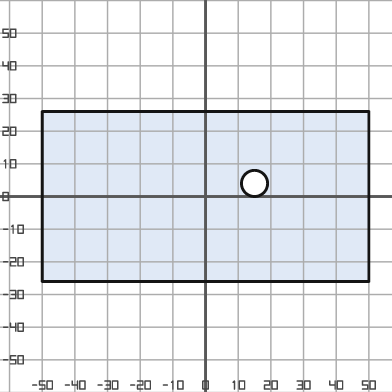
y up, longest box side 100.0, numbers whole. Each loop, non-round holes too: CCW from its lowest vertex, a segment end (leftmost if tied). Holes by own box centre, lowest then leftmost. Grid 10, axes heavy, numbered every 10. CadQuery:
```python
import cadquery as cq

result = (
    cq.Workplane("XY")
    .moveTo(-50.0, -26.0)
    .lineTo(50.0, -26.0)
    .lineTo(50.0, 26.0)
    .lineTo(-50.0, 26.0)
    .close()
    .moveTo(15.0, 4.0)
    .circle(4.0)
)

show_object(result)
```